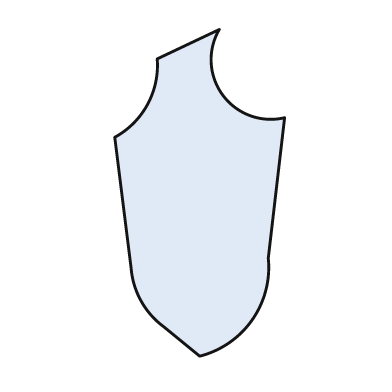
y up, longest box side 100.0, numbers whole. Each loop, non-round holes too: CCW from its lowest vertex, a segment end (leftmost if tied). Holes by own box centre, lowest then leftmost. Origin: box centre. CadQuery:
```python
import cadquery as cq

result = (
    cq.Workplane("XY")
    .moveTo(0.0, -50.0)
    .threePointArc((16.0, -39.0), (21.0, -20.0))
    .lineTo(26.0, 23.0)
    .threePointArc((7.0, 30.0), (6.0, 50.0))
    .lineTo(-13.0, 41.0)
    .threePointArc((-16.0, 27.0), (-26.0, 17.0))
    .lineTo(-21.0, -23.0)
    .threePointArc((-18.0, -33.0), (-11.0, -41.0))
    .close()
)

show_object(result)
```